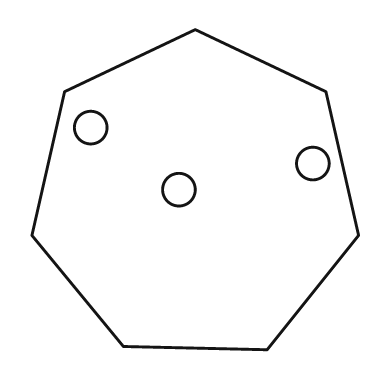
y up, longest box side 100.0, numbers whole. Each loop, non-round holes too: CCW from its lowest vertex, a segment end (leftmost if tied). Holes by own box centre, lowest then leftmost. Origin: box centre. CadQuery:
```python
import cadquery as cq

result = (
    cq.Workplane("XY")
    .moveTo(22.0, -49.0)
    .lineTo(50.0, -14.0)
    .lineTo(40.0, 30.0)
    .lineTo(0.0, 49.0)
    .lineTo(-40.0, 30.0)
    .lineTo(-50.0, -14.0)
    .lineTo(-22.0, -48.0)
    .close()
    .moveTo(-5.0, 0.0)
    .circle(5.0)
    .moveTo(36.0, 8.0)
    .circle(5.0)
    .moveTo(-32.0, 19.0)
    .circle(5.0)
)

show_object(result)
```